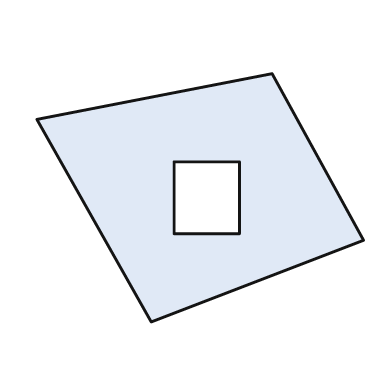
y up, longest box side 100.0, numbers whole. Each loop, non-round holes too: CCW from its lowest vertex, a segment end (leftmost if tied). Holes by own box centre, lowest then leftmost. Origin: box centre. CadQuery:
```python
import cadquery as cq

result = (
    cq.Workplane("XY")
    .moveTo(-15.0, -38.0)
    .lineTo(50.0, -13.0)
    .lineTo(22.0, 38.0)
    .lineTo(-50.0, 24.0)
    .close()
    .moveTo(-8.0, -11.0)
    .lineTo(12.0, -11.0)
    .lineTo(12.0, 11.0)
    .lineTo(-8.0, 11.0)
    .close()
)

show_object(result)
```